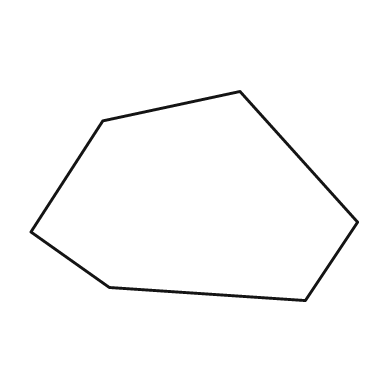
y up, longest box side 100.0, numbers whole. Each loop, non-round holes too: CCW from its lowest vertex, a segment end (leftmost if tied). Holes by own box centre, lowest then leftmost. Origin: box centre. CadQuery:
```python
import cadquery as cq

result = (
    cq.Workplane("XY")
    .moveTo(34.0, -32.0)
    .lineTo(50.0, -8.0)
    .lineTo(14.0, 32.0)
    .lineTo(-28.0, 23.0)
    .lineTo(-50.0, -11.0)
    .lineTo(-26.0, -28.0)
    .close()
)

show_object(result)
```